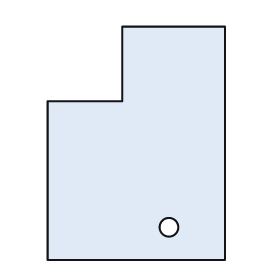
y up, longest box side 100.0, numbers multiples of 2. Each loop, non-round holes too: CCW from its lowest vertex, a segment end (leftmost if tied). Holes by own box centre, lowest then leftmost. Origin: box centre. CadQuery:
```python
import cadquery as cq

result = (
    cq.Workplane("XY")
    .moveTo(-38.0, -50.0)
    .lineTo(38.0, -50.0)
    .lineTo(38.0, 50.0)
    .lineTo(-6.0, 50.0)
    .lineTo(-6.0, 18.0)
    .lineTo(-38.0, 18.0)
    .close()
    .moveTo(14.0, -36.0)
    .circle(4.0)
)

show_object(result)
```